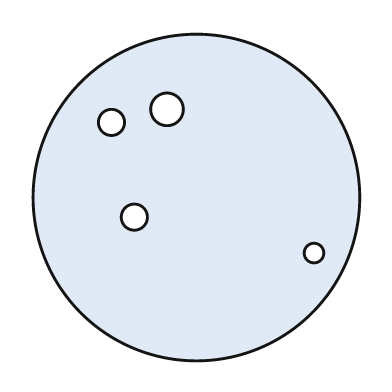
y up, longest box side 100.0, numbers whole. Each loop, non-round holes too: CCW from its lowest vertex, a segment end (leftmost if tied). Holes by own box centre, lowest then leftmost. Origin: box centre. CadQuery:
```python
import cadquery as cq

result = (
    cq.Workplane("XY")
    .moveTo(0.0, 0.0)
    .circle(50.0)
    .moveTo(36.0, -17.0)
    .circle(3.0)
    .moveTo(-19.0, -6.0)
    .circle(4.0)
    .moveTo(-26.0, 23.0)
    .circle(4.0)
    .moveTo(-9.0, 27.0)
    .circle(5.0)
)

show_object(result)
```